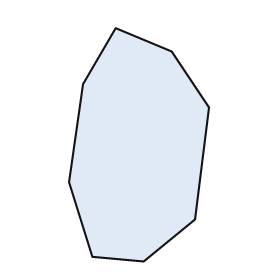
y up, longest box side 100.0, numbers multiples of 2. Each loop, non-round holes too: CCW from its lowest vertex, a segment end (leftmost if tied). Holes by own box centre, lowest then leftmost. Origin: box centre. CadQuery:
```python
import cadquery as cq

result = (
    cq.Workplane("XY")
    .moveTo(2.0, -50.0)
    .lineTo(24.0, -32.0)
    .lineTo(30.0, 16.0)
    .lineTo(14.0, 40.0)
    .lineTo(-10.0, 50.0)
    .lineTo(-24.0, 26.0)
    .lineTo(-30.0, -16.0)
    .lineTo(-20.0, -48.0)
    .close()
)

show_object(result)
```